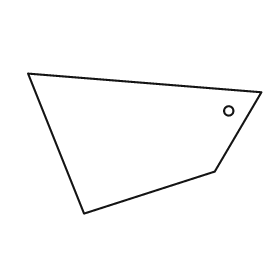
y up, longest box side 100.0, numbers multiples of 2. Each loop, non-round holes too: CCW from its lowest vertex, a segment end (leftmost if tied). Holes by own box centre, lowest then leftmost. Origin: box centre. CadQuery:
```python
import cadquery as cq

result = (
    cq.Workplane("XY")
    .moveTo(-26.0, -30.0)
    .lineTo(30.0, -12.0)
    .lineTo(50.0, 22.0)
    .lineTo(-50.0, 30.0)
    .close()
    .moveTo(36.0, 14.0)
    .circle(2.0)
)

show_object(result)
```